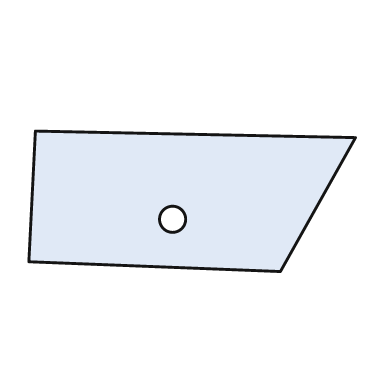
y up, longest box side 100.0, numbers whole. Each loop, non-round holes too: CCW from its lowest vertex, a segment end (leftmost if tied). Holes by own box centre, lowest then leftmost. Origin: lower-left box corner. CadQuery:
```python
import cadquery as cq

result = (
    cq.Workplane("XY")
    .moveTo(77.0, 0.0)
    .lineTo(100.0, 41.0)
    .lineTo(2.0, 43.0)
    .lineTo(0.0, 3.0)
    .close()
    .moveTo(44.0, 16.0)
    .circle(4.0)
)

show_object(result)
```